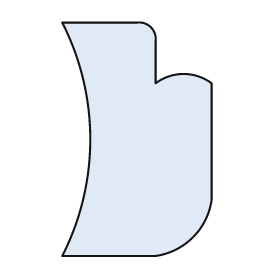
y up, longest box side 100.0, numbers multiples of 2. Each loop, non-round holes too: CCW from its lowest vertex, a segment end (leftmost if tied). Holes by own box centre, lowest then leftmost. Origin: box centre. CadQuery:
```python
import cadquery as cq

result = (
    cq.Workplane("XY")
    .moveTo(-32.0, -50.0)
    .lineTo(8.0, -50.0)
    .threePointArc((24.0, -42.0), (32.0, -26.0))
    .lineTo(32.0, 24.0)
    .threePointArc((20.0, 28.0), (8.0, 24.0))
    .lineTo(8.0, 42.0)
    .threePointArc((6.0, 48.0), (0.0, 50.0))
    .lineTo(-32.0, 50.0)
    .threePointArc((-20.0, 0.0), (-32.0, -50.0))
    .close()
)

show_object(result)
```